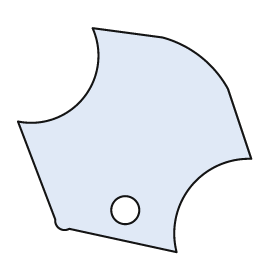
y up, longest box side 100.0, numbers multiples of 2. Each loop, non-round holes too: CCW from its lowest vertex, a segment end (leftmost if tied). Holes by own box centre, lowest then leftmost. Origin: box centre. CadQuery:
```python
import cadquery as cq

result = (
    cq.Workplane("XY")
    .moveTo(18.0, -48.0)
    .threePointArc((24.0, -20.0), (50.0, -8.0))
    .lineTo(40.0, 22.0)
    .threePointArc((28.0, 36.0), (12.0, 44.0))
    .lineTo(-18.0, 48.0)
    .threePointArc((-22.0, 18.0), (-50.0, 8.0))
    .lineTo(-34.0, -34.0)
    .threePointArc((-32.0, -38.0), (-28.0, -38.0))
    .close()
    .moveTo(-4.0, -30.0)
    .circle(6.0)
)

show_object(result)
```